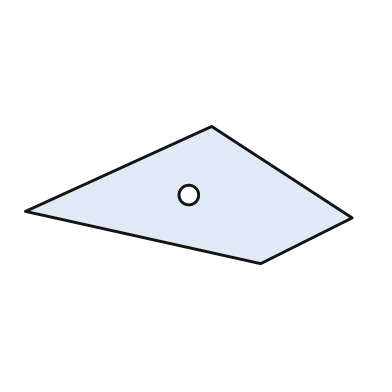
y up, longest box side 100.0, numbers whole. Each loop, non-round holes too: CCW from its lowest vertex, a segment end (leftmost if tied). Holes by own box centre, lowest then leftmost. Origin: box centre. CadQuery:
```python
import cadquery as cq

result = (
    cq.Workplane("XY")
    .moveTo(22.0, -21.0)
    .lineTo(50.0, -7.0)
    .lineTo(7.0, 21.0)
    .lineTo(-50.0, -5.0)
    .close()
    .moveTo(0.0, 0.0)
    .circle(3.0)
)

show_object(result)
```